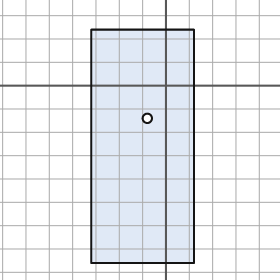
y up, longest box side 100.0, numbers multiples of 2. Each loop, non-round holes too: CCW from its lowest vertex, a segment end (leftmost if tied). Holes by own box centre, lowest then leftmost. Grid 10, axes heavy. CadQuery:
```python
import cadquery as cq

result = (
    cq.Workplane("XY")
    .moveTo(-32.0, -76.0)
    .lineTo(12.0, -76.0)
    .lineTo(12.0, 24.0)
    .lineTo(-32.0, 24.0)
    .close()
    .moveTo(-8.0, -14.0)
    .circle(2.0)
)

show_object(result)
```